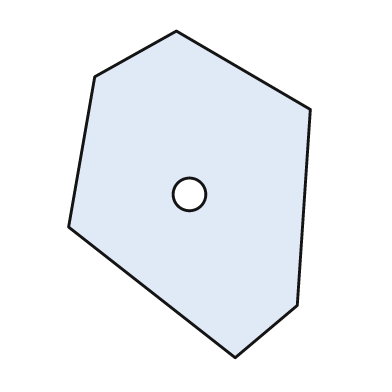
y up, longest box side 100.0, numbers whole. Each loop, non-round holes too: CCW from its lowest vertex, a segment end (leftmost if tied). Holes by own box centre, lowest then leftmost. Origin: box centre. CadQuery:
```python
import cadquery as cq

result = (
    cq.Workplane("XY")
    .moveTo(14.0, -50.0)
    .lineTo(33.0, -34.0)
    .lineTo(37.0, 26.0)
    .lineTo(-4.0, 50.0)
    .lineTo(-29.0, 36.0)
    .lineTo(-37.0, -10.0)
    .close()
    .moveTo(0.0, 0.0)
    .circle(5.0)
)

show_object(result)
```